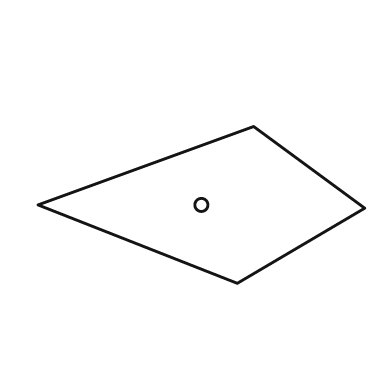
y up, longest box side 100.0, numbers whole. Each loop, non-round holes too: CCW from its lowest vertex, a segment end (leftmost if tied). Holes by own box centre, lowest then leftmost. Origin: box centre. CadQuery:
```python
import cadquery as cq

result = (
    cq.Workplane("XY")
    .moveTo(11.0, -24.0)
    .lineTo(50.0, -1.0)
    .lineTo(16.0, 24.0)
    .lineTo(-50.0, 0.0)
    .close()
    .moveTo(0.0, 0.0)
    .circle(2.0)
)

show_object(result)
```